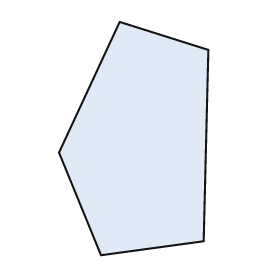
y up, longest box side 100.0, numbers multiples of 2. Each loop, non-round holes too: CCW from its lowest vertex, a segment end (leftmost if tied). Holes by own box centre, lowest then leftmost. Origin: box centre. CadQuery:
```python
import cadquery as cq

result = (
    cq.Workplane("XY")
    .moveTo(-14.0, -50.0)
    .lineTo(30.0, -44.0)
    .lineTo(32.0, 38.0)
    .lineTo(-6.0, 50.0)
    .lineTo(-32.0, -6.0)
    .close()
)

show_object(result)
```